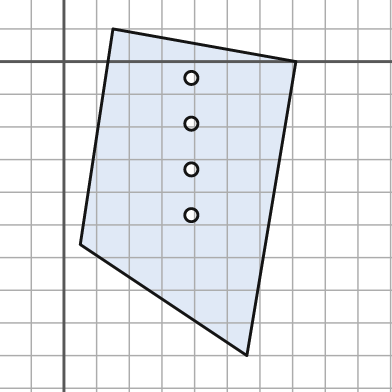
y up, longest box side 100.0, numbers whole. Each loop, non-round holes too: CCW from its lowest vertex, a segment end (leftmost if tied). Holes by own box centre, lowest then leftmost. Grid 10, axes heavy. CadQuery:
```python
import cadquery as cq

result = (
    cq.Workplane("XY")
    .moveTo(56.0, -90.0)
    .lineTo(71.0, 0.0)
    .lineTo(15.0, 10.0)
    .lineTo(5.0, -56.0)
    .close()
    .moveTo(39.0, -47.0)
    .circle(2.0)
    .moveTo(39.0, -33.0)
    .circle(2.0)
    .moveTo(39.0, -19.0)
    .circle(2.0)
    .moveTo(39.0, -5.0)
    .circle(2.0)
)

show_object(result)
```